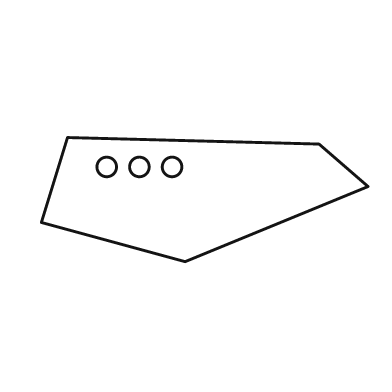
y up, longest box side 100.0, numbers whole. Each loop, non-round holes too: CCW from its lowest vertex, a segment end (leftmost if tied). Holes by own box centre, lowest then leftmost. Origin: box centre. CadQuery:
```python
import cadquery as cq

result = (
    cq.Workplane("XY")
    .moveTo(-6.0, -19.0)
    .lineTo(50.0, 4.0)
    .lineTo(35.0, 17.0)
    .lineTo(-42.0, 19.0)
    .lineTo(-50.0, -7.0)
    .close()
    .moveTo(-30.0, 10.0)
    .circle(3.0)
    .moveTo(-20.0, 10.0)
    .circle(3.0)
    .moveTo(-10.0, 10.0)
    .circle(3.0)
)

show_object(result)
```